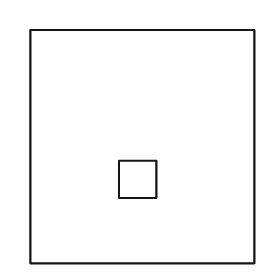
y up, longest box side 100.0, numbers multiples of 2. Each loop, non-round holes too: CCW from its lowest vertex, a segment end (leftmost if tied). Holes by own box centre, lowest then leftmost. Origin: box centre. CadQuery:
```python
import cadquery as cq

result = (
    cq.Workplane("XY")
    .moveTo(-48.0, -50.0)
    .lineTo(48.0, -50.0)
    .lineTo(48.0, 50.0)
    .lineTo(-48.0, 50.0)
    .close()
    .moveTo(-10.0, -22.0)
    .lineTo(6.0, -22.0)
    .lineTo(6.0, -6.0)
    .lineTo(-10.0, -6.0)
    .close()
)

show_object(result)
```